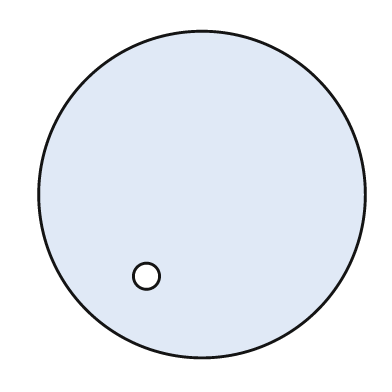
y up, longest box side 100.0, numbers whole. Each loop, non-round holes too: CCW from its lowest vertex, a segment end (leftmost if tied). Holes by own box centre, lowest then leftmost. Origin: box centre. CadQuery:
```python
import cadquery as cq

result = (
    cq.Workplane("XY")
    .moveTo(0.0, 0.0)
    .circle(50.0)
    .moveTo(-17.0, -25.0)
    .circle(4.0)
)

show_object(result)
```